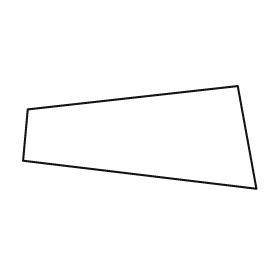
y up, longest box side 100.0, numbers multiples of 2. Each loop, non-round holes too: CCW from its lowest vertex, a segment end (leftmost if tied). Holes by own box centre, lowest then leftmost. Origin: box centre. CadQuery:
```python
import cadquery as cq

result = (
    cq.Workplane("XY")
    .moveTo(50.0, -22.0)
    .lineTo(42.0, 22.0)
    .lineTo(-48.0, 12.0)
    .lineTo(-50.0, -10.0)
    .close()
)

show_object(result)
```